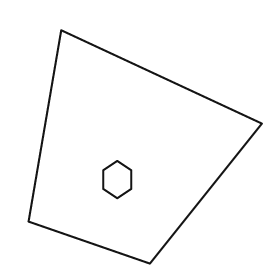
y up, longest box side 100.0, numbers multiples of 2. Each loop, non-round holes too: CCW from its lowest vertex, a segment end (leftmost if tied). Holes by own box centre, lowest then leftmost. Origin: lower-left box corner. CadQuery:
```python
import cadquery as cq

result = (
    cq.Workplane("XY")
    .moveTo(52.0, 0.0)
    .lineTo(100.0, 60.0)
    .lineTo(14.0, 100.0)
    .lineTo(0.0, 18.0)
    .close()
    .moveTo(38.0, 28.0)
    .lineTo(44.0, 32.0)
    .lineTo(44.0, 40.0)
    .lineTo(38.0, 44.0)
    .lineTo(32.0, 40.0)
    .lineTo(32.0, 32.0)
    .close()
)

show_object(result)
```